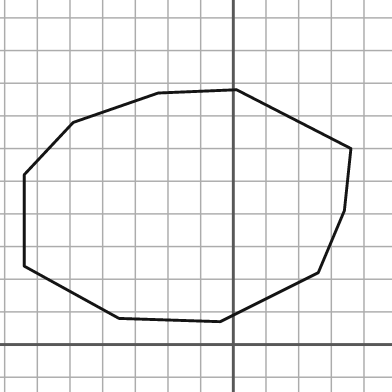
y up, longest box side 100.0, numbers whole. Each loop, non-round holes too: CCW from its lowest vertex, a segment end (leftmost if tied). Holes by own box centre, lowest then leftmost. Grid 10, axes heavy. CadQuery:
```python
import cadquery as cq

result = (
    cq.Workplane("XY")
    .moveTo(-4.0, 7.0)
    .lineTo(26.0, 22.0)
    .lineTo(34.0, 41.0)
    .lineTo(36.0, 60.0)
    .lineTo(1.0, 78.0)
    .lineTo(-23.0, 77.0)
    .lineTo(-49.0, 68.0)
    .lineTo(-64.0, 52.0)
    .lineTo(-64.0, 24.0)
    .lineTo(-35.0, 8.0)
    .close()
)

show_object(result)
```